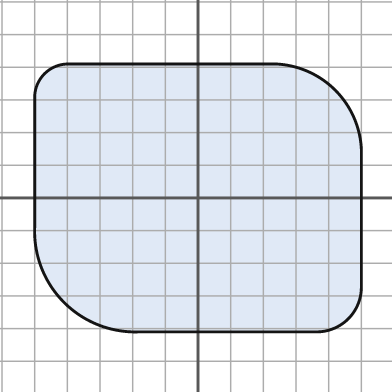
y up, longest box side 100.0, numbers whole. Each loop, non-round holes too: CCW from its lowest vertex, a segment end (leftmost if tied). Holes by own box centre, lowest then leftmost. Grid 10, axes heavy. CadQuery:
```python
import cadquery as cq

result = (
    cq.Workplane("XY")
    .moveTo(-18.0, -41.0)
    .lineTo(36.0, -41.0)
    .threePointArc((46.0, -37.0), (50.0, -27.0))
    .lineTo(50.0, 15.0)
    .threePointArc((42.0, 33.0), (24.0, 41.0))
    .lineTo(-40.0, 41.0)
    .threePointArc((-47.0, 38.0), (-50.0, 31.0))
    .lineTo(-50.0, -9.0)
    .threePointArc((-41.0, -32.0), (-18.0, -41.0))
    .close()
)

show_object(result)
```